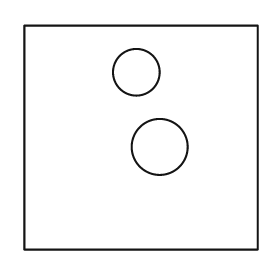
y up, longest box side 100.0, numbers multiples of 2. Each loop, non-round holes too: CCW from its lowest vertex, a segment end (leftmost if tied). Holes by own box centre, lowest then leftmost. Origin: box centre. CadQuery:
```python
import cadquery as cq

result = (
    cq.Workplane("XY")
    .moveTo(-50.0, -48.0)
    .lineTo(50.0, -48.0)
    .lineTo(50.0, 48.0)
    .lineTo(-50.0, 48.0)
    .close()
    .moveTo(8.0, -4.0)
    .circle(12.0)
    .moveTo(-2.0, 28.0)
    .circle(10.0)
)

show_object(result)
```